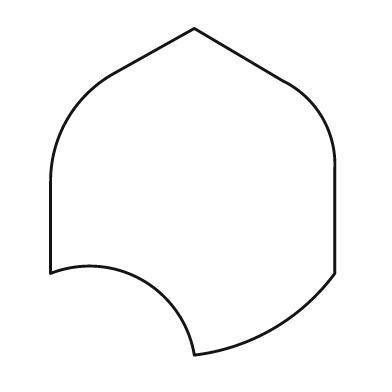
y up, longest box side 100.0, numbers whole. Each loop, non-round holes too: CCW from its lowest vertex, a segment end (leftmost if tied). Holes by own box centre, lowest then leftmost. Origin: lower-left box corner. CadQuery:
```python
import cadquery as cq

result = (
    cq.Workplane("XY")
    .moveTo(44.0, 0.0)
    .threePointArc((68.0, 8.0), (87.0, 25.0))
    .lineTo(87.0, 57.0)
    .threePointArc((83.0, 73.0), (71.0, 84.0))
    .lineTo(44.0, 100.0)
    .lineTo(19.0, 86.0)
    .threePointArc((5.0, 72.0), (0.0, 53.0))
    .lineTo(0.0, 25.0)
    .threePointArc((28.0, 23.0), (44.0, 0.0))
    .close()
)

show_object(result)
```